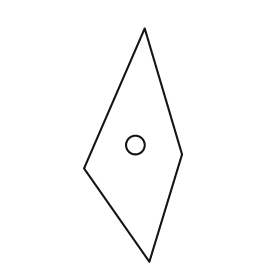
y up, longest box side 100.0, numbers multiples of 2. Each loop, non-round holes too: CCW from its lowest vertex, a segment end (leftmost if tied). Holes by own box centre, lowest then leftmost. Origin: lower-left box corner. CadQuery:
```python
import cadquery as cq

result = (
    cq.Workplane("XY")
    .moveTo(28.0, 0.0)
    .lineTo(42.0, 46.0)
    .lineTo(26.0, 100.0)
    .lineTo(0.0, 40.0)
    .close()
    .moveTo(22.0, 50.0)
    .circle(4.0)
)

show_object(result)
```